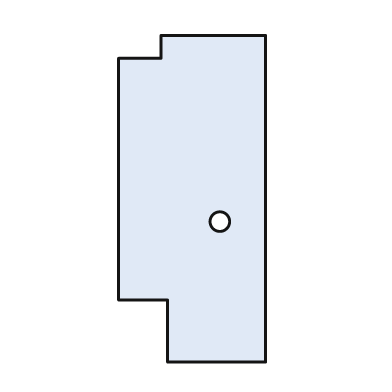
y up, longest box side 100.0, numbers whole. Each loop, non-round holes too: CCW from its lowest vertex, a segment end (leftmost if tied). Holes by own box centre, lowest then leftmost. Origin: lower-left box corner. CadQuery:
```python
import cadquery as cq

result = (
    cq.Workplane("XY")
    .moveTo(15.0, 0.0)
    .lineTo(45.0, 0.0)
    .lineTo(45.0, 100.0)
    .lineTo(13.0, 100.0)
    .lineTo(13.0, 93.0)
    .lineTo(0.0, 93.0)
    .lineTo(0.0, 19.0)
    .lineTo(15.0, 19.0)
    .close()
    .moveTo(31.0, 43.0)
    .circle(3.0)
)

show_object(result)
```